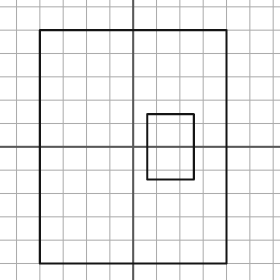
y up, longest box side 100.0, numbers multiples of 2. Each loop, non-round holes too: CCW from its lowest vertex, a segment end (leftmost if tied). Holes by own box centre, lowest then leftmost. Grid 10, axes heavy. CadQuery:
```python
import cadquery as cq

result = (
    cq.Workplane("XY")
    .moveTo(-40.0, -50.0)
    .lineTo(40.0, -50.0)
    .lineTo(40.0, 50.0)
    .lineTo(-40.0, 50.0)
    .close()
    .moveTo(6.0, -14.0)
    .lineTo(26.0, -14.0)
    .lineTo(26.0, 14.0)
    .lineTo(6.0, 14.0)
    .close()
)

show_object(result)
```